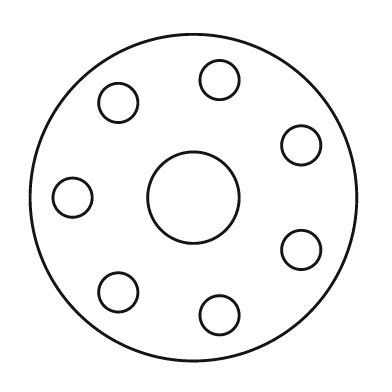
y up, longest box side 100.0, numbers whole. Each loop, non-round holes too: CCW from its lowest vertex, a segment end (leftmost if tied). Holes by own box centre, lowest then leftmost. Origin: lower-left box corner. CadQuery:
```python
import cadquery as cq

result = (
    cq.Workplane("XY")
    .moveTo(50.0, 50.0)
    .circle(50.0)
    .moveTo(58.0, 14.0)
    .circle(6.0)
    .moveTo(27.0, 21.0)
    .circle(6.0)
    .moveTo(83.0, 34.0)
    .circle(6.0)
    .moveTo(13.0, 50.0)
    .circle(6.0)
    .moveTo(50.0, 50.0)
    .circle(14.0)
    .moveTo(83.0, 66.0)
    .circle(6.0)
    .moveTo(27.0, 79.0)
    .circle(6.0)
    .moveTo(58.0, 86.0)
    .circle(6.0)
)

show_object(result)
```